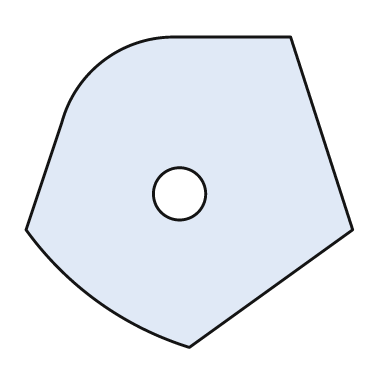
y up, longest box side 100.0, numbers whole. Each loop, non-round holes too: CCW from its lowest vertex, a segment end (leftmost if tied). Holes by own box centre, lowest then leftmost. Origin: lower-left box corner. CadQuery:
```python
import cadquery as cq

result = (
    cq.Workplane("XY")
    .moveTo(50.0, 0.0)
    .lineTo(100.0, 36.0)
    .lineTo(81.0, 95.0)
    .lineTo(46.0, 95.0)
    .threePointArc((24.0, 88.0), (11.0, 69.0))
    .lineTo(0.0, 36.0)
    .threePointArc((22.0, 14.0), (50.0, 0.0))
    .close()
    .moveTo(47.0, 47.0)
    .circle(8.0)
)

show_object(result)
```